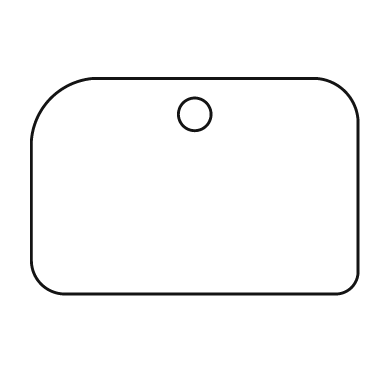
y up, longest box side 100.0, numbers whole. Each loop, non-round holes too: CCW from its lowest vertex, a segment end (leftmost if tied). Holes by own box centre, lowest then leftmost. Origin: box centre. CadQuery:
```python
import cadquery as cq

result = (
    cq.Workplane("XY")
    .moveTo(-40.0, -33.0)
    .lineTo(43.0, -33.0)
    .threePointArc((48.0, -31.0), (50.0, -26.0))
    .lineTo(50.0, 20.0)
    .threePointArc((46.0, 29.0), (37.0, 33.0))
    .lineTo(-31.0, 33.0)
    .threePointArc((-44.0, 27.0), (-50.0, 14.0))
    .lineTo(-50.0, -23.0)
    .threePointArc((-47.0, -30.0), (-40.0, -33.0))
    .close()
    .moveTo(0.0, 22.0)
    .circle(5.0)
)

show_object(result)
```